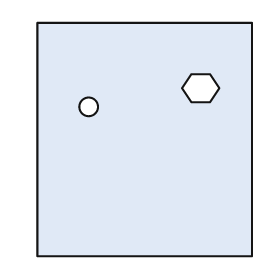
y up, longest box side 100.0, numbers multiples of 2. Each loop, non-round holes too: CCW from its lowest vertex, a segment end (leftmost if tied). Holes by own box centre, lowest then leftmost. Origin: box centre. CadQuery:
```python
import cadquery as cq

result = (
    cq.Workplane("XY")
    .moveTo(-46.0, -50.0)
    .lineTo(46.0, -50.0)
    .lineTo(46.0, 50.0)
    .lineTo(-46.0, 50.0)
    .close()
    .moveTo(-24.0, 14.0)
    .circle(4.0)
    .moveTo(20.0, 16.0)
    .lineTo(28.0, 16.0)
    .lineTo(32.0, 22.0)
    .lineTo(28.0, 28.0)
    .lineTo(20.0, 28.0)
    .lineTo(16.0, 22.0)
    .close()
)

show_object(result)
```